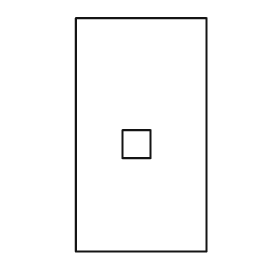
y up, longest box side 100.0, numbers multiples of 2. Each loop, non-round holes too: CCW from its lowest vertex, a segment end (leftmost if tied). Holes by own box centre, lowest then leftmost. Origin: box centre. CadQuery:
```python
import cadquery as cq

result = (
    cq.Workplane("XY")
    .moveTo(-28.0, -50.0)
    .lineTo(28.0, -50.0)
    .lineTo(28.0, 50.0)
    .lineTo(-28.0, 50.0)
    .close()
    .moveTo(-8.0, -10.0)
    .lineTo(4.0, -10.0)
    .lineTo(4.0, 2.0)
    .lineTo(-8.0, 2.0)
    .close()
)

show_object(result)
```